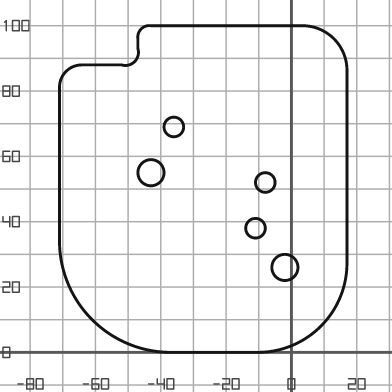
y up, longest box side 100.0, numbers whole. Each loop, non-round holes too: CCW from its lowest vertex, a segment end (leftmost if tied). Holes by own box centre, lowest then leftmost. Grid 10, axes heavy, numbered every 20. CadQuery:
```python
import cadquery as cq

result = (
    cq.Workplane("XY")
    .moveTo(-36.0, 0.0)
    .lineTo(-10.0, 0.0)
    .threePointArc((9.0, 8.0), (17.0, 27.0))
    .lineTo(17.0, 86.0)
    .threePointArc((13.0, 96.0), (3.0, 100.0))
    .lineTo(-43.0, 100.0)
    .threePointArc((-46.0, 99.0), (-47.0, 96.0))
    .lineTo(-47.0, 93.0)
    .threePointArc((-48.0, 89.0), (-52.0, 88.0))
    .lineTo(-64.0, 88.0)
    .threePointArc((-69.0, 86.0), (-71.0, 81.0))
    .lineTo(-71.0, 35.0)
    .threePointArc((-61.0, 10.0), (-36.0, 0.0))
    .close()
    .moveTo(-2.0, 26.0)
    .circle(4.0)
    .moveTo(-11.0, 38.0)
    .circle(3.0)
    .moveTo(-8.0, 52.0)
    .circle(3.0)
    .moveTo(-43.0, 55.0)
    .circle(4.0)
    .moveTo(-36.0, 69.0)
    .circle(3.0)
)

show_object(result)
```